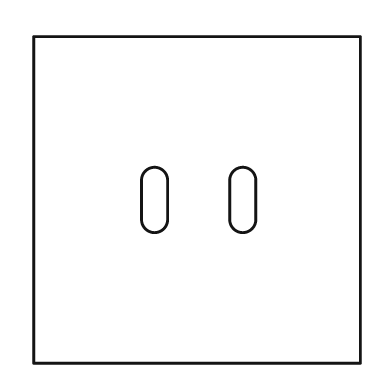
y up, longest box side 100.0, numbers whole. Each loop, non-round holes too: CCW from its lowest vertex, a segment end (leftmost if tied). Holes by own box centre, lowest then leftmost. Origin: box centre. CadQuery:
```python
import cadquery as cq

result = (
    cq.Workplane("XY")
    .moveTo(-50.0, -50.0)
    .lineTo(50.0, -50.0)
    .lineTo(50.0, 50.0)
    .lineTo(-50.0, 50.0)
    .close()
    .moveTo(-17.0, -6.0)
    .threePointArc((-13.0, -10.0), (-9.0, -6.0))
    .lineTo(-9.0, 6.0)
    .threePointArc((-13.0, 10.0), (-17.0, 6.0))
    .close()
    .moveTo(10.0, -6.0)
    .threePointArc((14.0, -10.0), (18.0, -6.0))
    .lineTo(18.0, 6.0)
    .threePointArc((14.0, 10.0), (10.0, 6.0))
    .close()
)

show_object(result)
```